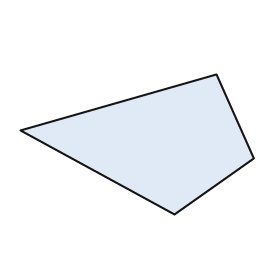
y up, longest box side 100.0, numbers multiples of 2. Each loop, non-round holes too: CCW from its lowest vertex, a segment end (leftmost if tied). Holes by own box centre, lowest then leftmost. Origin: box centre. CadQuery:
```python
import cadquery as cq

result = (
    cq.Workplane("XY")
    .moveTo(16.0, -30.0)
    .lineTo(50.0, -6.0)
    .lineTo(34.0, 30.0)
    .lineTo(-50.0, 6.0)
    .close()
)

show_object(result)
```